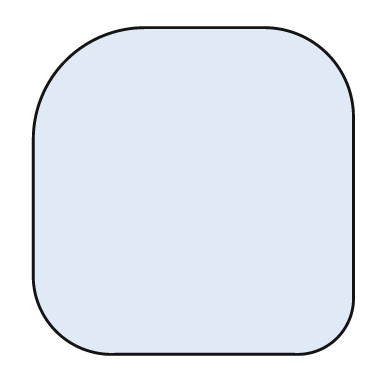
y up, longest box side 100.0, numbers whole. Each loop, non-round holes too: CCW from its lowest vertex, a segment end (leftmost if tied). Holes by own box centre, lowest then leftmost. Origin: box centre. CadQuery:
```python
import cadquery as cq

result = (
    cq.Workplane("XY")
    .moveTo(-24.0, -50.0)
    .lineTo(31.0, -50.0)
    .threePointArc((44.0, -45.0), (49.0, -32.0))
    .lineTo(49.0, 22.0)
    .threePointArc((41.0, 42.0), (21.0, 50.0))
    .lineTo(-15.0, 50.0)
    .threePointArc((-39.0, 40.0), (-49.0, 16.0))
    .lineTo(-49.0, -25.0)
    .threePointArc((-42.0, -43.0), (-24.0, -50.0))
    .close()
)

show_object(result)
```